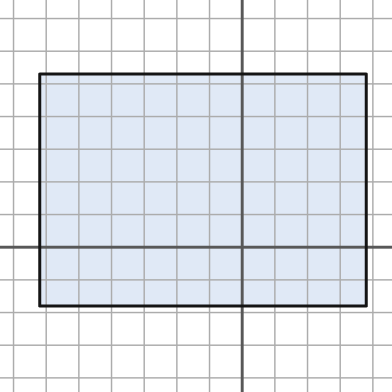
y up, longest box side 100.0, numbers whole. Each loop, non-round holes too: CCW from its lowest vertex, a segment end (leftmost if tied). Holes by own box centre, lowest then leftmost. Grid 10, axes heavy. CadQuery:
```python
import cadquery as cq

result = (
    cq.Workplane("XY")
    .moveTo(-62.0, -18.0)
    .lineTo(38.0, -18.0)
    .lineTo(38.0, 53.0)
    .lineTo(-62.0, 53.0)
    .close()
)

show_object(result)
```